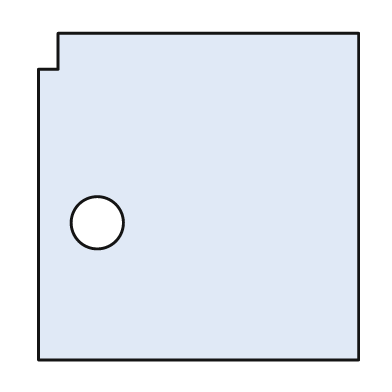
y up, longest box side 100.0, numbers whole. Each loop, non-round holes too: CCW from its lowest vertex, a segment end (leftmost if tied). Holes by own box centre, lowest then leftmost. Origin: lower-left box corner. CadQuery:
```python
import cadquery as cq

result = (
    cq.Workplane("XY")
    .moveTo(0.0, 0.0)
    .lineTo(98.0, 0.0)
    .lineTo(98.0, 100.0)
    .lineTo(6.0, 100.0)
    .lineTo(6.0, 89.0)
    .lineTo(0.0, 89.0)
    .close()
    .moveTo(18.0, 42.0)
    .circle(8.0)
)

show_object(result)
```